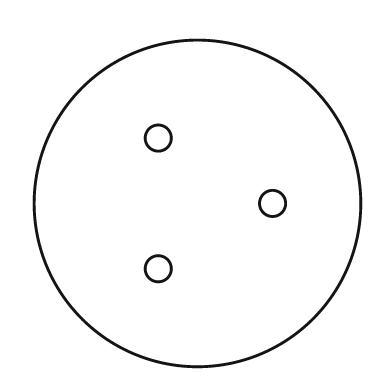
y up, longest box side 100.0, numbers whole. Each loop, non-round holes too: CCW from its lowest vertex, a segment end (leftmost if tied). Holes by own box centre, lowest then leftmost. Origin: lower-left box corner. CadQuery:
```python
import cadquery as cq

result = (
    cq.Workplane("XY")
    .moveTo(50.0, 50.0)
    .circle(50.0)
    .moveTo(38.0, 30.0)
    .circle(4.0)
    .moveTo(73.0, 50.0)
    .circle(4.0)
    .moveTo(38.0, 70.0)
    .circle(4.0)
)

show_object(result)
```